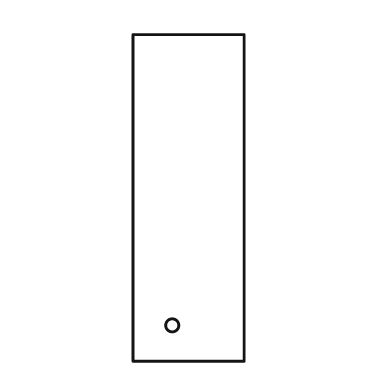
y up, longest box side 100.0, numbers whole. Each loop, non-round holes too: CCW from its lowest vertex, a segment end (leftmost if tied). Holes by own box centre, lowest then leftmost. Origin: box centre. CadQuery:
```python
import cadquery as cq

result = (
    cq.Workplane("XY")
    .moveTo(-17.0, -50.0)
    .lineTo(17.0, -50.0)
    .lineTo(17.0, 50.0)
    .lineTo(-17.0, 50.0)
    .close()
    .moveTo(-5.0, -39.0)
    .circle(2.0)
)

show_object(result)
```